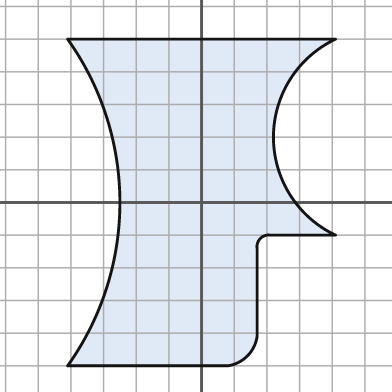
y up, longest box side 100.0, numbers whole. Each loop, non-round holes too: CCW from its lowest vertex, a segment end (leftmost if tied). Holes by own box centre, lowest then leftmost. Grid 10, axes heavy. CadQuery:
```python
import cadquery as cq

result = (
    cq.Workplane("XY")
    .moveTo(-41.0, -50.0)
    .lineTo(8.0, -50.0)
    .threePointArc((14.0, -47.0), (17.0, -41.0))
    .lineTo(17.0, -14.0)
    .threePointArc((18.0, -11.0), (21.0, -10.0))
    .lineTo(41.0, -10.0)
    .threePointArc((22.0, 20.0), (41.0, 50.0))
    .lineTo(-41.0, 50.0)
    .threePointArc((-25.0, 0.0), (-41.0, -50.0))
    .close()
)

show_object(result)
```